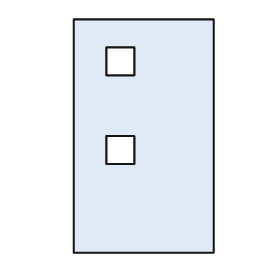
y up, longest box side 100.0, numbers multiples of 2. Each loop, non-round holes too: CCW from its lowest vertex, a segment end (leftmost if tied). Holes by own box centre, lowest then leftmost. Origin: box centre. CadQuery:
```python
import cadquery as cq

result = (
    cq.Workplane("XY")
    .moveTo(-30.0, -50.0)
    .lineTo(30.0, -50.0)
    .lineTo(30.0, 50.0)
    .lineTo(-30.0, 50.0)
    .close()
    .moveTo(-16.0, -12.0)
    .lineTo(-4.0, -12.0)
    .lineTo(-4.0, 0.0)
    .lineTo(-16.0, 0.0)
    .close()
    .moveTo(-16.0, 26.0)
    .lineTo(-4.0, 26.0)
    .lineTo(-4.0, 38.0)
    .lineTo(-16.0, 38.0)
    .close()
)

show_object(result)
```